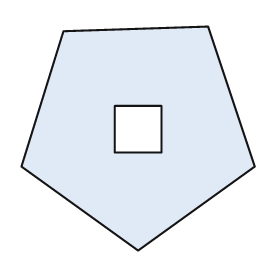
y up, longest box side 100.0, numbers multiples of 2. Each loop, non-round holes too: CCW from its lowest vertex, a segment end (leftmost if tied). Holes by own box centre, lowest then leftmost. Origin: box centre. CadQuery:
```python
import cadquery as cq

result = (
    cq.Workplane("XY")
    .moveTo(0.0, -48.0)
    .lineTo(50.0, -12.0)
    .lineTo(30.0, 48.0)
    .lineTo(-32.0, 46.0)
    .lineTo(-50.0, -12.0)
    .close()
    .moveTo(-10.0, -6.0)
    .lineTo(10.0, -6.0)
    .lineTo(10.0, 14.0)
    .lineTo(-10.0, 14.0)
    .close()
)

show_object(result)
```